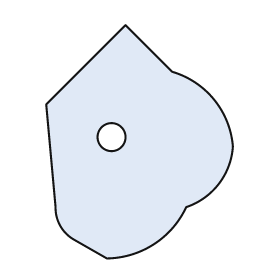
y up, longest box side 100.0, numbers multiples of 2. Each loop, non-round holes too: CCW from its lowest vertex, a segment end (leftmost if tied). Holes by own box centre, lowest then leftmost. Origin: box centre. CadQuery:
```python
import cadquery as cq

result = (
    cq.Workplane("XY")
    .moveTo(-14.0, -50.0)
    .threePointArc((6.0, -44.0), (20.0, -28.0))
    .threePointArc((34.0, -18.0), (40.0, -2.0))
    .threePointArc((32.0, 18.0), (14.0, 30.0))
    .lineTo(-6.0, 50.0)
    .lineTo(-40.0, 16.0)
    .lineTo(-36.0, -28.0)
    .threePointArc((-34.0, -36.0), (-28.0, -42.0))
    .close()
    .moveTo(-12.0, 2.0)
    .circle(6.0)
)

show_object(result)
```